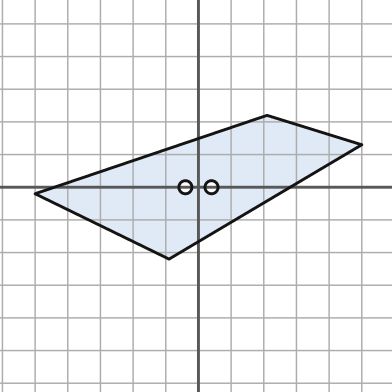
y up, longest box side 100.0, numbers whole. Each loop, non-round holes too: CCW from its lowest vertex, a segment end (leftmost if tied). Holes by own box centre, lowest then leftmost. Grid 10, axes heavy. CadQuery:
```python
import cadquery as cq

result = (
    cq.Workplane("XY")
    .moveTo(-9.0, -22.0)
    .lineTo(50.0, 13.0)
    .lineTo(21.0, 22.0)
    .lineTo(-50.0, -2.0)
    .close()
    .moveTo(-4.0, 0.0)
    .circle(2.0)
    .moveTo(4.0, 0.0)
    .circle(2.0)
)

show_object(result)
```